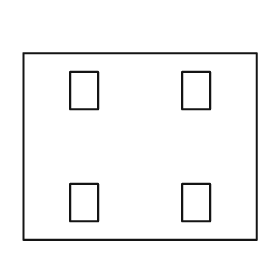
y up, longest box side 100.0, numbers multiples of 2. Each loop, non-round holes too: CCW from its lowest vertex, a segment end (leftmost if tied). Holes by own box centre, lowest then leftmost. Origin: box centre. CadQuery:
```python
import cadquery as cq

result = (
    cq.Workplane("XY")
    .moveTo(-50.0, -40.0)
    .lineTo(50.0, -40.0)
    .lineTo(50.0, 40.0)
    .lineTo(-50.0, 40.0)
    .close()
    .moveTo(-30.0, -32.0)
    .lineTo(-18.0, -32.0)
    .lineTo(-18.0, -16.0)
    .lineTo(-30.0, -16.0)
    .close()
    .moveTo(18.0, -32.0)
    .lineTo(30.0, -32.0)
    .lineTo(30.0, -16.0)
    .lineTo(18.0, -16.0)
    .close()
    .moveTo(-30.0, 16.0)
    .lineTo(-18.0, 16.0)
    .lineTo(-18.0, 32.0)
    .lineTo(-30.0, 32.0)
    .close()
    .moveTo(18.0, 16.0)
    .lineTo(30.0, 16.0)
    .lineTo(30.0, 32.0)
    .lineTo(18.0, 32.0)
    .close()
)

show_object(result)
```